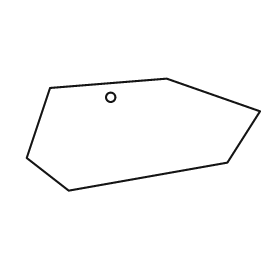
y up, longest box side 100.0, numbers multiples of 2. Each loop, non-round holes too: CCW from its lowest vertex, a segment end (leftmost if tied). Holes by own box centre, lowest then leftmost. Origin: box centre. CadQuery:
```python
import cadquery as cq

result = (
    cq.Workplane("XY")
    .moveTo(-32.0, -24.0)
    .lineTo(36.0, -12.0)
    .lineTo(50.0, 10.0)
    .lineTo(10.0, 24.0)
    .lineTo(-40.0, 20.0)
    .lineTo(-50.0, -10.0)
    .close()
    .moveTo(-14.0, 16.0)
    .circle(2.0)
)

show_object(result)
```